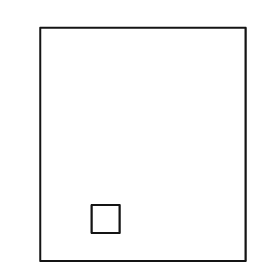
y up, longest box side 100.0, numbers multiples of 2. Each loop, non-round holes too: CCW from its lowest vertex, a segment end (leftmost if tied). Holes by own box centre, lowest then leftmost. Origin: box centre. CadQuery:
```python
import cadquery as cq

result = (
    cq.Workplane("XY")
    .moveTo(-44.0, -50.0)
    .lineTo(44.0, -50.0)
    .lineTo(44.0, 50.0)
    .lineTo(-44.0, 50.0)
    .close()
    .moveTo(-22.0, -38.0)
    .lineTo(-10.0, -38.0)
    .lineTo(-10.0, -26.0)
    .lineTo(-22.0, -26.0)
    .close()
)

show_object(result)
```